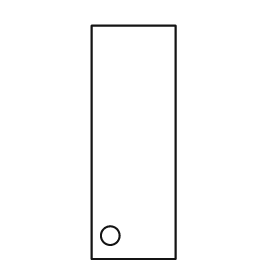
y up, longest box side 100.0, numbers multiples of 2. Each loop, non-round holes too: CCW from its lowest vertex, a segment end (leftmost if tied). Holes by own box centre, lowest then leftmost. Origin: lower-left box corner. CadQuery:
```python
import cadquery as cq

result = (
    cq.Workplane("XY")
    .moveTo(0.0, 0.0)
    .lineTo(36.0, 0.0)
    .lineTo(36.0, 100.0)
    .lineTo(0.0, 100.0)
    .close()
    .moveTo(8.0, 10.0)
    .circle(4.0)
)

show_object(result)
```